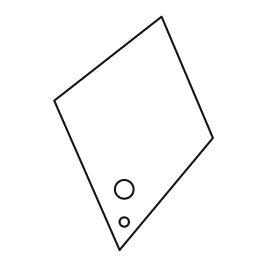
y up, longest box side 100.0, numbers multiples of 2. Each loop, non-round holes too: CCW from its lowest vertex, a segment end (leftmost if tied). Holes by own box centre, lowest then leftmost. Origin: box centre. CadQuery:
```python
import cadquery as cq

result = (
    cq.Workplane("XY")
    .moveTo(-6.0, -50.0)
    .lineTo(34.0, -2.0)
    .lineTo(12.0, 50.0)
    .lineTo(-34.0, 14.0)
    .close()
    .moveTo(-4.0, -38.0)
    .circle(2.0)
    .moveTo(-4.0, -24.0)
    .circle(4.0)
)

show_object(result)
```